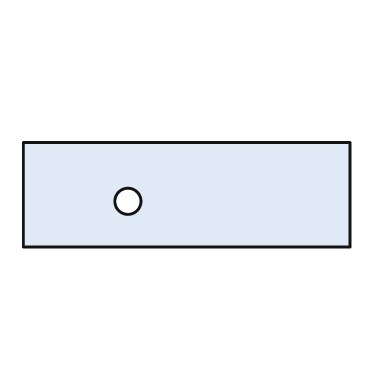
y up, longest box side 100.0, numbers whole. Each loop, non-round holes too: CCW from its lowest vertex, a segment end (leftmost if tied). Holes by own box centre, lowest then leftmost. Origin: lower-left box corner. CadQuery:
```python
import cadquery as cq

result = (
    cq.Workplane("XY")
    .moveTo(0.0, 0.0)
    .lineTo(100.0, 0.0)
    .lineTo(100.0, 32.0)
    .lineTo(0.0, 32.0)
    .close()
    .moveTo(32.0, 14.0)
    .circle(4.0)
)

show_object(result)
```